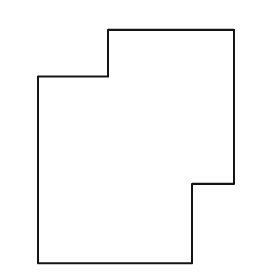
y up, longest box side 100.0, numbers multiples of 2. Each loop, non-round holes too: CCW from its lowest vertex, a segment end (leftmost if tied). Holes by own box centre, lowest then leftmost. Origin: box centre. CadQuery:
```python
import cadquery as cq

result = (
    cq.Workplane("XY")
    .moveTo(-42.0, -50.0)
    .lineTo(24.0, -50.0)
    .lineTo(24.0, -16.0)
    .lineTo(42.0, -16.0)
    .lineTo(42.0, 50.0)
    .lineTo(-12.0, 50.0)
    .lineTo(-12.0, 30.0)
    .lineTo(-42.0, 30.0)
    .close()
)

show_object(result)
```